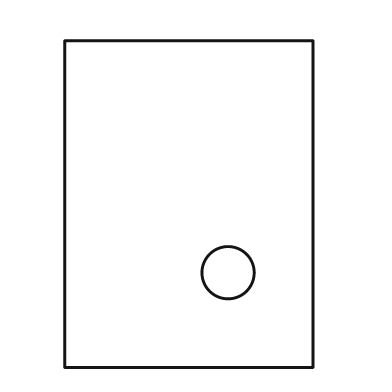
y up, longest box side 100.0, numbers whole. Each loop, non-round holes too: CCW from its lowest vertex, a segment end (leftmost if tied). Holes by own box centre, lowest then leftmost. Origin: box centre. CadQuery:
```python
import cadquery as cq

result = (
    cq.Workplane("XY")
    .moveTo(-38.0, -50.0)
    .lineTo(38.0, -50.0)
    .lineTo(38.0, 50.0)
    .lineTo(-38.0, 50.0)
    .close()
    .moveTo(12.0, -21.0)
    .circle(8.0)
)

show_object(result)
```